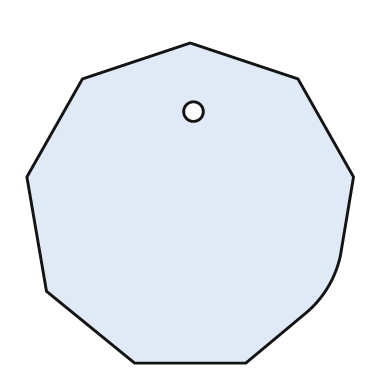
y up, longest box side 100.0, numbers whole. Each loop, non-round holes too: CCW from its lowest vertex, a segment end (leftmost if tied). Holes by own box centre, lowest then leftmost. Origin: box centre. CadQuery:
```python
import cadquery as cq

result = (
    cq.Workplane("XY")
    .moveTo(-17.0, -49.0)
    .lineTo(17.0, -49.0)
    .lineTo(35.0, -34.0)
    .threePointArc((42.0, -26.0), (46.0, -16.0))
    .lineTo(50.0, 8.0)
    .lineTo(33.0, 38.0)
    .lineTo(0.0, 49.0)
    .lineTo(-33.0, 38.0)
    .lineTo(-50.0, 8.0)
    .lineTo(-44.0, -27.0)
    .close()
    .moveTo(1.0, 28.0)
    .circle(3.0)
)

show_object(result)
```